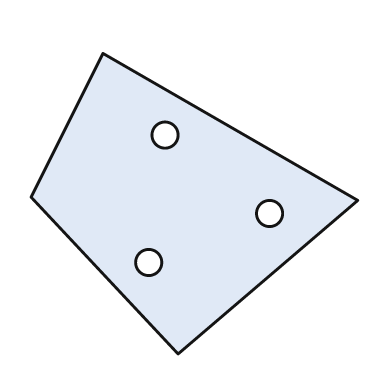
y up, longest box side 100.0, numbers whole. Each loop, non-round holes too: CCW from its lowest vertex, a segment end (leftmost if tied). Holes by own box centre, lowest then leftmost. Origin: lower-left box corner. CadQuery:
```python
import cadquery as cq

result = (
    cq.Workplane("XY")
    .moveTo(45.0, 0.0)
    .lineTo(100.0, 47.0)
    .lineTo(22.0, 92.0)
    .lineTo(0.0, 48.0)
    .close()
    .moveTo(36.0, 28.0)
    .circle(4.0)
    .moveTo(73.0, 43.0)
    .circle(4.0)
    .moveTo(41.0, 67.0)
    .circle(4.0)
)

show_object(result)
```